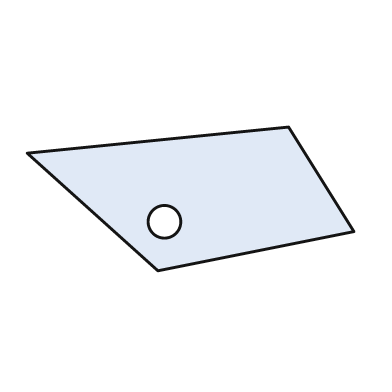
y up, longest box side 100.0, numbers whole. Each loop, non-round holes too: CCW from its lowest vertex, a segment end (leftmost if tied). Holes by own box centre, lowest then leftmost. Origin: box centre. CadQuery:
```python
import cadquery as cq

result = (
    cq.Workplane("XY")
    .moveTo(-10.0, -22.0)
    .lineTo(50.0, -10.0)
    .lineTo(30.0, 22.0)
    .lineTo(-50.0, 14.0)
    .close()
    .moveTo(-8.0, -7.0)
    .circle(5.0)
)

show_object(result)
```